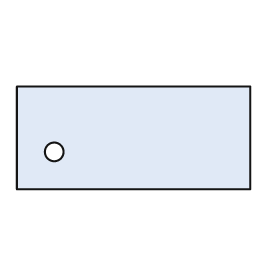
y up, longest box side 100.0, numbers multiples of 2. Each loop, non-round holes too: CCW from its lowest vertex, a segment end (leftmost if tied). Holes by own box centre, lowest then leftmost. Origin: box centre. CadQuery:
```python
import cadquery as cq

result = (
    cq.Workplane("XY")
    .moveTo(-50.0, -22.0)
    .lineTo(50.0, -22.0)
    .lineTo(50.0, 22.0)
    .lineTo(-50.0, 22.0)
    .close()
    .moveTo(-34.0, -6.0)
    .circle(4.0)
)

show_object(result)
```